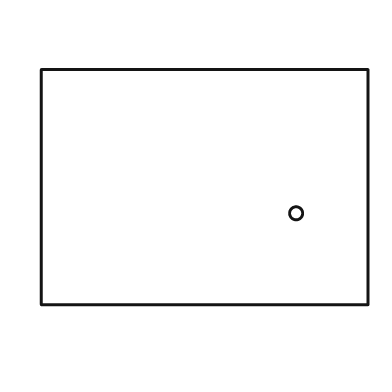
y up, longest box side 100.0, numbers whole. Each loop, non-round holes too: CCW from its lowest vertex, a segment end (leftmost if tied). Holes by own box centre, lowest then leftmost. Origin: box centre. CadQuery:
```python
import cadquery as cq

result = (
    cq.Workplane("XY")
    .moveTo(-50.0, -36.0)
    .lineTo(50.0, -36.0)
    .lineTo(50.0, 36.0)
    .lineTo(-50.0, 36.0)
    .close()
    .moveTo(28.0, -8.0)
    .circle(2.0)
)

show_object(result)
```